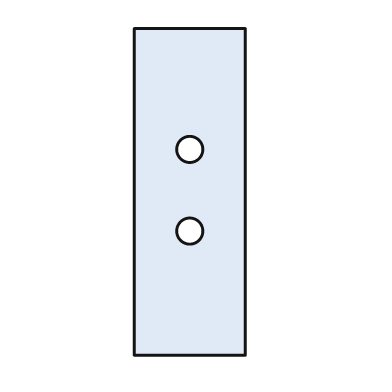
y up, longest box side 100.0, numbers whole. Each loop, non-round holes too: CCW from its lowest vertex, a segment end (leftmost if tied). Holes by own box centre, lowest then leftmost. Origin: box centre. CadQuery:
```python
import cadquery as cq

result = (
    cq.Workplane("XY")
    .moveTo(-17.0, -50.0)
    .lineTo(17.0, -50.0)
    .lineTo(17.0, 50.0)
    .lineTo(-17.0, 50.0)
    .close()
    .moveTo(0.0, -12.0)
    .circle(4.0)
    .moveTo(0.0, 13.0)
    .circle(4.0)
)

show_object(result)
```